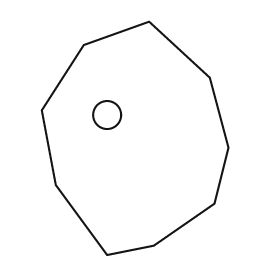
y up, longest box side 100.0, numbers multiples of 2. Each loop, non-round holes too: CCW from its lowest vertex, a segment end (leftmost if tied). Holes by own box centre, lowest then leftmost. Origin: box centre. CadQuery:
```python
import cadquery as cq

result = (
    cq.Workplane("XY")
    .moveTo(-12.0, -50.0)
    .lineTo(8.0, -46.0)
    .lineTo(34.0, -28.0)
    .lineTo(40.0, -4.0)
    .lineTo(32.0, 26.0)
    .lineTo(6.0, 50.0)
    .lineTo(-22.0, 40.0)
    .lineTo(-40.0, 12.0)
    .lineTo(-34.0, -20.0)
    .close()
    .moveTo(-12.0, 10.0)
    .circle(6.0)
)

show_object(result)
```